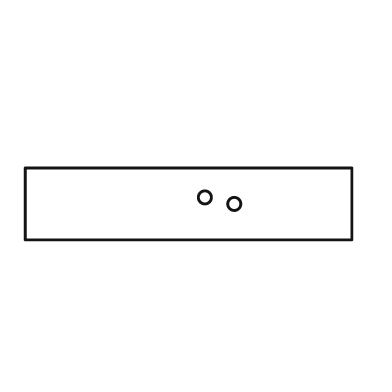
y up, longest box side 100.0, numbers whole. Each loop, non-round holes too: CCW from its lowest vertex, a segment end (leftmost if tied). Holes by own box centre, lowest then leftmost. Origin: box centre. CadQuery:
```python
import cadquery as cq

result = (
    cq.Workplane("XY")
    .moveTo(-50.0, -11.0)
    .lineTo(50.0, -11.0)
    .lineTo(50.0, 11.0)
    .lineTo(-50.0, 11.0)
    .close()
    .moveTo(14.0, 0.0)
    .circle(2.0)
    .moveTo(5.0, 2.0)
    .circle(2.0)
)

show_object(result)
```